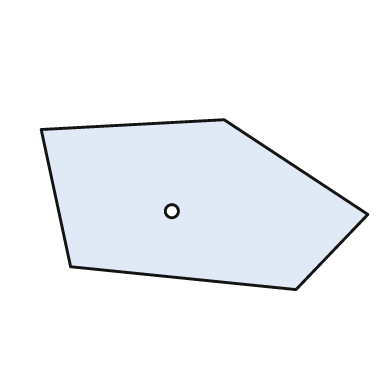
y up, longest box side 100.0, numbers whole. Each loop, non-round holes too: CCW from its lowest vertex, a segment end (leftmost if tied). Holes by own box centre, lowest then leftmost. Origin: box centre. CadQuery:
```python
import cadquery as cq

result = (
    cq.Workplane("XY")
    .moveTo(28.0, -26.0)
    .lineTo(50.0, -3.0)
    .lineTo(6.0, 26.0)
    .lineTo(-50.0, 23.0)
    .lineTo(-41.0, -19.0)
    .close()
    .moveTo(-10.0, -2.0)
    .circle(2.0)
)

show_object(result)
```